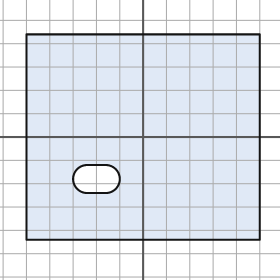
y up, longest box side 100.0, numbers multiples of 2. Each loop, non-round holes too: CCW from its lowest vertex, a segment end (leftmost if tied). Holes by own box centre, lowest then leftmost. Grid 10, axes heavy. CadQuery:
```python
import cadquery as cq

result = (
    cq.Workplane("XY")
    .moveTo(-50.0, -44.0)
    .lineTo(50.0, -44.0)
    .lineTo(50.0, 44.0)
    .lineTo(-50.0, 44.0)
    .close()
    .moveTo(-24.0, -24.0)
    .lineTo(-16.0, -24.0)
    .threePointArc((-10.0, -18.0), (-16.0, -12.0))
    .lineTo(-24.0, -12.0)
    .threePointArc((-30.0, -18.0), (-24.0, -24.0))
    .close()
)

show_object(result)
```